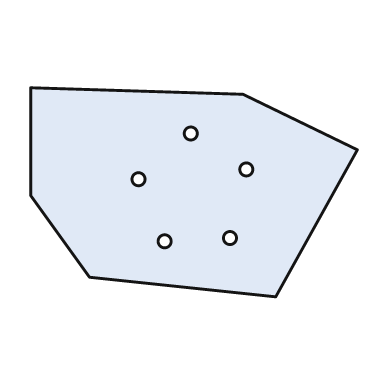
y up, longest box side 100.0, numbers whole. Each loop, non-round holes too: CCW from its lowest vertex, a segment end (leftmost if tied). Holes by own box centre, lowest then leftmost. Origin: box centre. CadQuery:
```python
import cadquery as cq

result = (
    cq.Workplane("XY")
    .moveTo(25.0, -32.0)
    .lineTo(50.0, 13.0)
    .lineTo(15.0, 30.0)
    .lineTo(-50.0, 32.0)
    .lineTo(-50.0, -1.0)
    .lineTo(-32.0, -26.0)
    .close()
    .moveTo(-9.0, -15.0)
    .circle(2.0)
    .moveTo(11.0, -14.0)
    .circle(2.0)
    .moveTo(-17.0, 4.0)
    .circle(2.0)
    .moveTo(16.0, 7.0)
    .circle(2.0)
    .moveTo(-1.0, 18.0)
    .circle(2.0)
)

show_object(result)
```